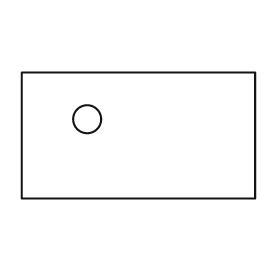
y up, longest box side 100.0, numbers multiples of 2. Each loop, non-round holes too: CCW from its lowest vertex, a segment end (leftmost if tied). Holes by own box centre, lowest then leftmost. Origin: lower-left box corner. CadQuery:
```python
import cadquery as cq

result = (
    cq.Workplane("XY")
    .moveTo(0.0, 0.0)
    .lineTo(100.0, 0.0)
    .lineTo(100.0, 54.0)
    .lineTo(0.0, 54.0)
    .close()
    .moveTo(28.0, 34.0)
    .circle(6.0)
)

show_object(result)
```